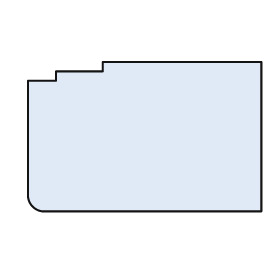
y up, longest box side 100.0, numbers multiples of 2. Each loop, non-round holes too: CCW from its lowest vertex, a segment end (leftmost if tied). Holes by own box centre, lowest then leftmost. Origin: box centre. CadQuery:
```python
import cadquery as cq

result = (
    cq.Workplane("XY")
    .moveTo(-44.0, -32.0)
    .lineTo(50.0, -32.0)
    .lineTo(50.0, 32.0)
    .lineTo(-18.0, 32.0)
    .lineTo(-18.0, 28.0)
    .lineTo(-38.0, 28.0)
    .lineTo(-38.0, 24.0)
    .lineTo(-50.0, 24.0)
    .lineTo(-50.0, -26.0)
    .threePointArc((-48.0, -30.0), (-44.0, -32.0))
    .close()
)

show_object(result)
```